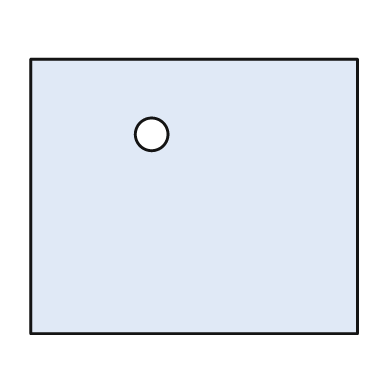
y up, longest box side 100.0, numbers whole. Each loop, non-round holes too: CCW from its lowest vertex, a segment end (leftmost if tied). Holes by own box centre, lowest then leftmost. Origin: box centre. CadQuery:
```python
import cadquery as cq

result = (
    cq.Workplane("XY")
    .moveTo(-50.0, -42.0)
    .lineTo(50.0, -42.0)
    .lineTo(50.0, 42.0)
    .lineTo(-50.0, 42.0)
    .close()
    .moveTo(-13.0, 19.0)
    .circle(5.0)
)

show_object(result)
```